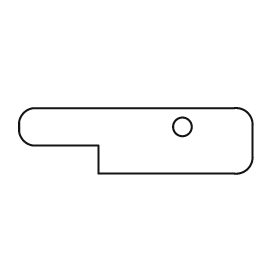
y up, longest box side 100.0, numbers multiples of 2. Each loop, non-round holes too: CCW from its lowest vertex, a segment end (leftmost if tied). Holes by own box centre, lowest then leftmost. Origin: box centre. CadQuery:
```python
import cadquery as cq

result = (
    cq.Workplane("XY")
    .moveTo(-16.0, -14.0)
    .lineTo(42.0, -14.0)
    .threePointArc((48.0, -12.0), (50.0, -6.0))
    .lineTo(50.0, 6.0)
    .threePointArc((48.0, 12.0), (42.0, 14.0))
    .lineTo(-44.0, 14.0)
    .threePointArc((-48.0, 12.0), (-50.0, 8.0))
    .lineTo(-50.0, 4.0)
    .threePointArc((-48.0, 0.0), (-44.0, -2.0))
    .lineTo(-16.0, -2.0)
    .close()
    .moveTo(20.0, 6.0)
    .circle(4.0)
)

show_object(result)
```